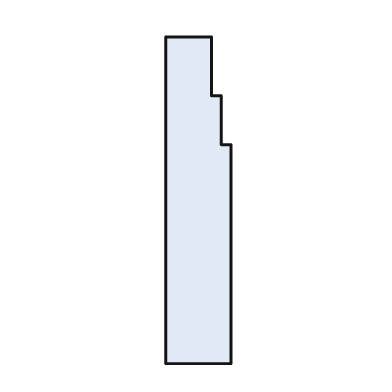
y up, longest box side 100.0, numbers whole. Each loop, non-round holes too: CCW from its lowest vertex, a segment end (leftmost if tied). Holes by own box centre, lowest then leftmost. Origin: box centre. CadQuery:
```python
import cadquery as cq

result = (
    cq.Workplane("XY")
    .moveTo(-10.0, -50.0)
    .lineTo(10.0, -50.0)
    .lineTo(10.0, 17.0)
    .lineTo(7.0, 17.0)
    .lineTo(7.0, 32.0)
    .lineTo(4.0, 32.0)
    .lineTo(4.0, 50.0)
    .lineTo(-10.0, 50.0)
    .close()
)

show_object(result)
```